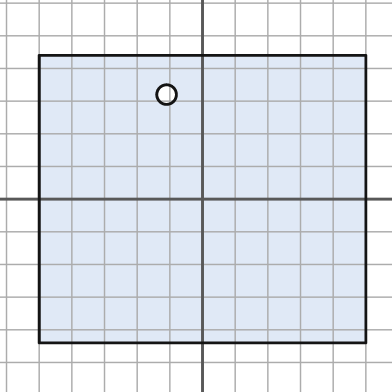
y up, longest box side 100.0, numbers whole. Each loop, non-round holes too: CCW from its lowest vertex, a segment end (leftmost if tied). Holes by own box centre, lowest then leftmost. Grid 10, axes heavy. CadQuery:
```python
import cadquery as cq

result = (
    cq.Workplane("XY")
    .moveTo(-50.0, -44.0)
    .lineTo(50.0, -44.0)
    .lineTo(50.0, 44.0)
    .lineTo(-50.0, 44.0)
    .close()
    .moveTo(-11.0, 32.0)
    .circle(3.0)
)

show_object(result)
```